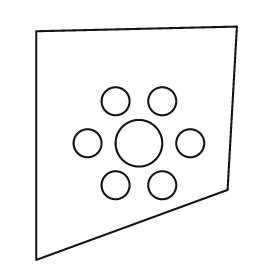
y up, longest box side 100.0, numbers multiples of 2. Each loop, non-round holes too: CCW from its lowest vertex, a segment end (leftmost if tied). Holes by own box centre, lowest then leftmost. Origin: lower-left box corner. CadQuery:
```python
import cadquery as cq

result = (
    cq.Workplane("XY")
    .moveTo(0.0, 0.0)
    .lineTo(82.0, 30.0)
    .lineTo(86.0, 100.0)
    .lineTo(0.0, 98.0)
    .close()
    .moveTo(34.0, 32.0)
    .circle(6.0)
    .moveTo(54.0, 32.0)
    .circle(6.0)
    .moveTo(22.0, 50.0)
    .circle(6.0)
    .moveTo(44.0, 50.0)
    .circle(10.0)
    .moveTo(66.0, 50.0)
    .circle(6.0)
    .moveTo(34.0, 68.0)
    .circle(6.0)
    .moveTo(54.0, 68.0)
    .circle(6.0)
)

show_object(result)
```